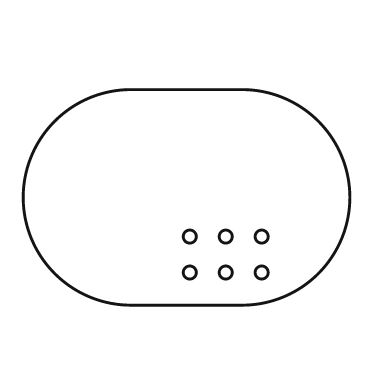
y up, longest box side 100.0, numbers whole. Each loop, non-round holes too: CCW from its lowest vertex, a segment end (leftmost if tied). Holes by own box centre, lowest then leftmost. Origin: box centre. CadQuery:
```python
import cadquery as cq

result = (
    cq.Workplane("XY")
    .moveTo(-17.0, -33.0)
    .lineTo(17.0, -33.0)
    .threePointArc((50.0, 0.0), (17.0, 33.0))
    .lineTo(-17.0, 33.0)
    .threePointArc((-50.0, 0.0), (-17.0, -33.0))
    .close()
    .moveTo(1.0, -23.0)
    .circle(2.0)
    .moveTo(12.0, -23.0)
    .circle(2.0)
    .moveTo(23.0, -23.0)
    .circle(2.0)
    .moveTo(1.0, -12.0)
    .circle(2.0)
    .moveTo(12.0, -12.0)
    .circle(2.0)
    .moveTo(23.0, -12.0)
    .circle(2.0)
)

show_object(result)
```